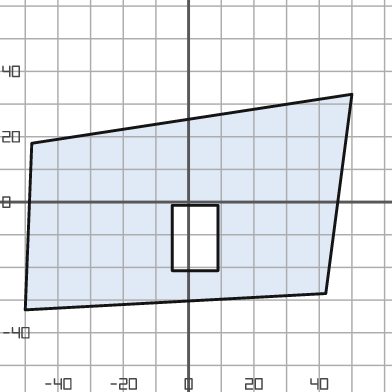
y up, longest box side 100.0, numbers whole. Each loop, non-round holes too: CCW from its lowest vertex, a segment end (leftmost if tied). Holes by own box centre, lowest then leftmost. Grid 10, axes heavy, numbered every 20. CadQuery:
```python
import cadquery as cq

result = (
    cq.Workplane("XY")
    .moveTo(-50.0, -33.0)
    .lineTo(42.0, -28.0)
    .lineTo(50.0, 33.0)
    .lineTo(-48.0, 18.0)
    .close()
    .moveTo(-5.0, -21.0)
    .lineTo(9.0, -21.0)
    .lineTo(9.0, -1.0)
    .lineTo(-5.0, -1.0)
    .close()
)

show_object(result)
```